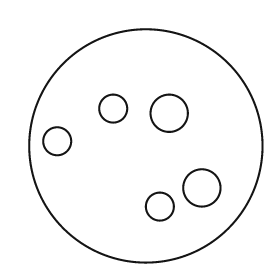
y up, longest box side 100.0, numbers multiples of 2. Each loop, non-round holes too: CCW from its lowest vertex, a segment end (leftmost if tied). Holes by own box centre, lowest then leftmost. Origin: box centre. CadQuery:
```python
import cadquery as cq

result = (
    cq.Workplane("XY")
    .moveTo(0.0, 0.0)
    .circle(50.0)
    .moveTo(6.0, -26.0)
    .circle(6.0)
    .moveTo(24.0, -18.0)
    .circle(8.0)
    .moveTo(-38.0, 2.0)
    .circle(6.0)
    .moveTo(10.0, 14.0)
    .circle(8.0)
    .moveTo(-14.0, 16.0)
    .circle(6.0)
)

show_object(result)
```